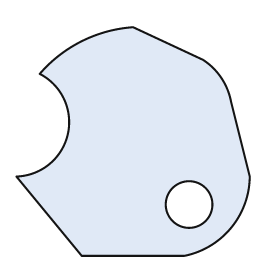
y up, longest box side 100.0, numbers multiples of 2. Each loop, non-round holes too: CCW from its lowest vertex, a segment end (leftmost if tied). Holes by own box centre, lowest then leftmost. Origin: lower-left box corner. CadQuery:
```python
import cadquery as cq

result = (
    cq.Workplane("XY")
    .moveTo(28.0, 0.0)
    .lineTo(72.0, 0.0)
    .threePointArc((92.0, 12.0), (100.0, 34.0))
    .lineTo(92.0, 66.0)
    .threePointArc((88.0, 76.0), (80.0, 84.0))
    .lineTo(50.0, 98.0)
    .threePointArc((28.0, 92.0), (10.0, 78.0))
    .threePointArc((22.0, 52.0), (0.0, 34.0))
    .close()
    .moveTo(74.0, 22.0)
    .circle(10.0)
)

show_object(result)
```